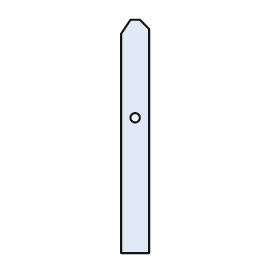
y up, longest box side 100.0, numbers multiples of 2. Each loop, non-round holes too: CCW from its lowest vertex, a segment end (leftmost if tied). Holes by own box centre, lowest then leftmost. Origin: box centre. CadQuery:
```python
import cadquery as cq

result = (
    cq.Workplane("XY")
    .moveTo(-6.0, -50.0)
    .lineTo(6.0, -50.0)
    .lineTo(6.0, 46.0)
    .lineTo(2.0, 50.0)
    .lineTo(-2.0, 50.0)
    .lineTo(-6.0, 44.0)
    .close()
    .moveTo(0.0, 8.0)
    .circle(2.0)
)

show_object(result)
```